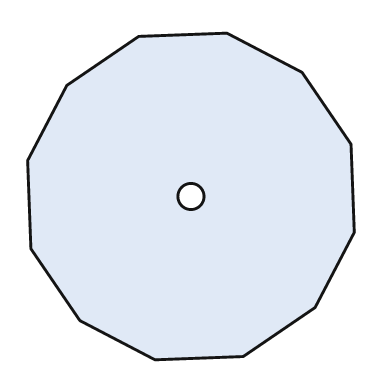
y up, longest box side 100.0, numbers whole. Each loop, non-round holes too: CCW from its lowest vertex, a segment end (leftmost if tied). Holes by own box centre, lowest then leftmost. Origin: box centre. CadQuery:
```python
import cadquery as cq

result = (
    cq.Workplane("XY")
    .moveTo(-11.0, -50.0)
    .lineTo(16.0, -49.0)
    .lineTo(38.0, -34.0)
    .lineTo(50.0, -11.0)
    .lineTo(49.0, 16.0)
    .lineTo(34.0, 38.0)
    .lineTo(11.0, 50.0)
    .lineTo(-16.0, 49.0)
    .lineTo(-38.0, 34.0)
    .lineTo(-50.0, 11.0)
    .lineTo(-49.0, -16.0)
    .lineTo(-34.0, -38.0)
    .close()
    .moveTo(0.0, 0.0)
    .circle(4.0)
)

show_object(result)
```